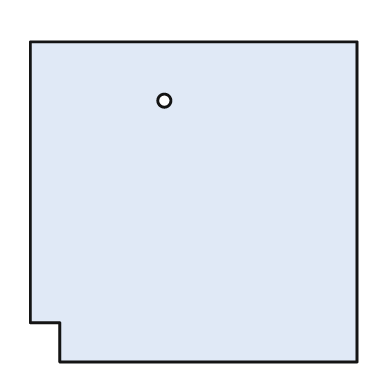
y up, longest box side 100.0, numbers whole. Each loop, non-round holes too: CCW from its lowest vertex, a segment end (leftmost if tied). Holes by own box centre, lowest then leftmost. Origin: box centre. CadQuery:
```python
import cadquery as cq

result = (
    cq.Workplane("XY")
    .moveTo(-41.0, -49.0)
    .lineTo(50.0, -49.0)
    .lineTo(50.0, 49.0)
    .lineTo(-50.0, 49.0)
    .lineTo(-50.0, -37.0)
    .lineTo(-41.0, -37.0)
    .close()
    .moveTo(-9.0, 31.0)
    .circle(2.0)
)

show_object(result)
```